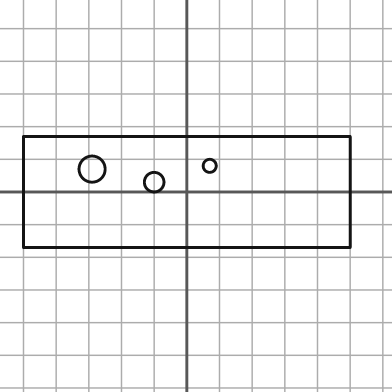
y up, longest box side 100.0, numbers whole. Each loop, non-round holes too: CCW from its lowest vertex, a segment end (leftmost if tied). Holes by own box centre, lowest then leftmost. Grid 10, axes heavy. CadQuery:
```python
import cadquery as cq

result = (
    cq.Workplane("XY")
    .moveTo(-50.0, -17.0)
    .lineTo(50.0, -17.0)
    .lineTo(50.0, 17.0)
    .lineTo(-50.0, 17.0)
    .close()
    .moveTo(-10.0, 3.0)
    .circle(3.0)
    .moveTo(-29.0, 7.0)
    .circle(4.0)
    .moveTo(7.0, 8.0)
    .circle(2.0)
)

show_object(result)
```